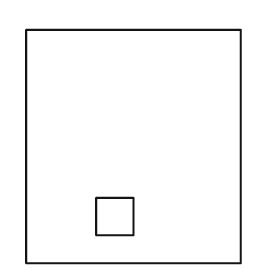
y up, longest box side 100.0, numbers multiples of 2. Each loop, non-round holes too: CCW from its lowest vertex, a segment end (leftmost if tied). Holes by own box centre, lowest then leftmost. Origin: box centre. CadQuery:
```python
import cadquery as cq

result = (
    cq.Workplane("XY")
    .moveTo(-46.0, -50.0)
    .lineTo(46.0, -50.0)
    .lineTo(46.0, 50.0)
    .lineTo(-46.0, 50.0)
    .close()
    .moveTo(-16.0, -38.0)
    .lineTo(0.0, -38.0)
    .lineTo(0.0, -22.0)
    .lineTo(-16.0, -22.0)
    .close()
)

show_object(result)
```